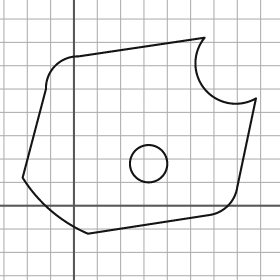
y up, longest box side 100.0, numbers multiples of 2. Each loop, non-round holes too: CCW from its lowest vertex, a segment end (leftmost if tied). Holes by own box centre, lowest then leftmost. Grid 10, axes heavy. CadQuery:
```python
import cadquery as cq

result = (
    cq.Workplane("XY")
    .moveTo(6.0, -12.0)
    .lineTo(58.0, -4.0)
    .threePointArc((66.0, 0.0), (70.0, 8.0))
    .lineTo(78.0, 46.0)
    .threePointArc((56.0, 50.0), (56.0, 72.0))
    .lineTo(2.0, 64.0)
    .threePointArc((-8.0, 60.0), (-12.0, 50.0))
    .lineTo(-22.0, 12.0)
    .threePointArc((-10.0, -2.0), (6.0, -12.0))
    .close()
    .moveTo(32.0, 18.0)
    .circle(8.0)
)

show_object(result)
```